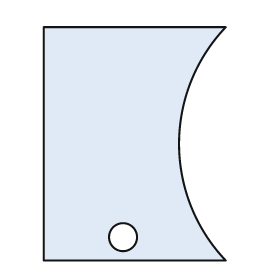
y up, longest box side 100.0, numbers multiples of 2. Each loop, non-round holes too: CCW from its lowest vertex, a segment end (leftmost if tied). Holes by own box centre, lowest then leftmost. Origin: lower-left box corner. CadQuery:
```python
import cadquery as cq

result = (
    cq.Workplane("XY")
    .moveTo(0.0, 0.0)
    .lineTo(78.0, 0.0)
    .threePointArc((58.0, 50.0), (78.0, 100.0))
    .lineTo(0.0, 100.0)
    .close()
    .moveTo(34.0, 10.0)
    .circle(6.0)
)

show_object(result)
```